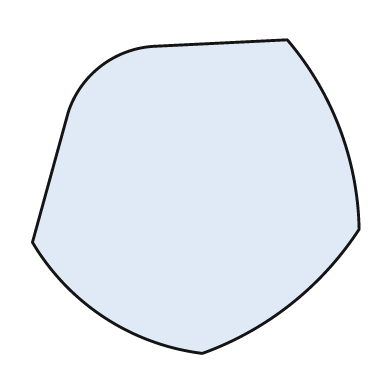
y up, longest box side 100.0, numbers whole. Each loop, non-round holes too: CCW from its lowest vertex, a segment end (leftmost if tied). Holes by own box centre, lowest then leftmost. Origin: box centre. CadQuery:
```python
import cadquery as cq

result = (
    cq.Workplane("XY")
    .moveTo(2.0, -48.0)
    .threePointArc((29.0, -33.0), (50.0, -10.0))
    .threePointArc((44.0, 21.0), (28.0, 48.0))
    .lineTo(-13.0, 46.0)
    .threePointArc((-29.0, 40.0), (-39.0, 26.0))
    .lineTo(-50.0, -14.0)
    .threePointArc((-28.0, -37.0), (2.0, -48.0))
    .close()
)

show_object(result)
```